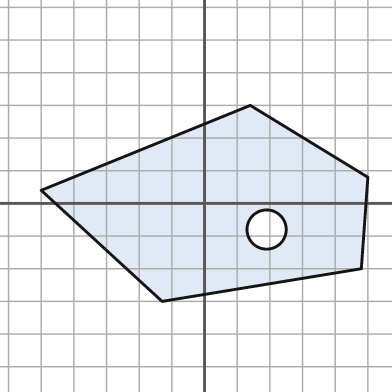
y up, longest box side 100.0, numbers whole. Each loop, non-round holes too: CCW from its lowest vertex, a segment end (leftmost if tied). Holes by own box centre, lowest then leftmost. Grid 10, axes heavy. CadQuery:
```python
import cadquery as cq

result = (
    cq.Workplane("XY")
    .moveTo(-13.0, -30.0)
    .lineTo(48.0, -20.0)
    .lineTo(50.0, 8.0)
    .lineTo(14.0, 30.0)
    .lineTo(-50.0, 4.0)
    .close()
    .moveTo(19.0, -8.0)
    .circle(6.0)
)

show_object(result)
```